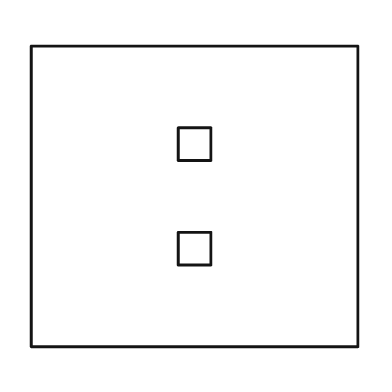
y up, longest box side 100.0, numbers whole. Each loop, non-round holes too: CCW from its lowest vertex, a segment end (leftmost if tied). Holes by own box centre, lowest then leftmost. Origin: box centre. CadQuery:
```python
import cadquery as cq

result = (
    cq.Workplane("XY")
    .moveTo(-50.0, -46.0)
    .lineTo(50.0, -46.0)
    .lineTo(50.0, 46.0)
    .lineTo(-50.0, 46.0)
    .close()
    .moveTo(-5.0, -21.0)
    .lineTo(5.0, -21.0)
    .lineTo(5.0, -11.0)
    .lineTo(-5.0, -11.0)
    .close()
    .moveTo(-5.0, 11.0)
    .lineTo(5.0, 11.0)
    .lineTo(5.0, 21.0)
    .lineTo(-5.0, 21.0)
    .close()
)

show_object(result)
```